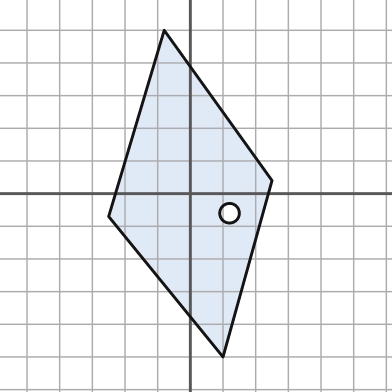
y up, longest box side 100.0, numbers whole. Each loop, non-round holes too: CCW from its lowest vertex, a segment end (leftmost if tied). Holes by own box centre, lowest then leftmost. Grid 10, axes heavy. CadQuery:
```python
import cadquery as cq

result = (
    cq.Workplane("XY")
    .moveTo(10.0, -50.0)
    .lineTo(25.0, 4.0)
    .lineTo(-8.0, 50.0)
    .lineTo(-25.0, -7.0)
    .close()
    .moveTo(12.0, -6.0)
    .circle(3.0)
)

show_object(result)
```